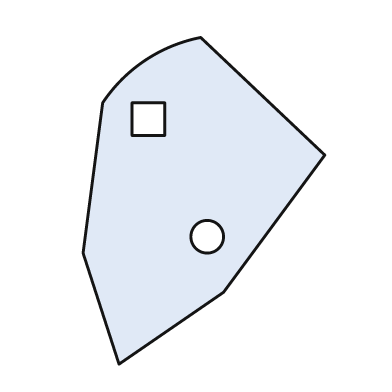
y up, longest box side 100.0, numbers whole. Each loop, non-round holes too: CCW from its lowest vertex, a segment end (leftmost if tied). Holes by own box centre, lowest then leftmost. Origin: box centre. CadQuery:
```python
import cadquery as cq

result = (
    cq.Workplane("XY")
    .moveTo(-26.0, -50.0)
    .lineTo(6.0, -28.0)
    .lineTo(37.0, 14.0)
    .lineTo(-1.0, 50.0)
    .threePointArc((-18.0, 43.0), (-31.0, 30.0))
    .lineTo(-37.0, -16.0)
    .close()
    .moveTo(1.0, -11.0)
    .circle(5.0)
    .moveTo(-22.0, 20.0)
    .lineTo(-12.0, 20.0)
    .lineTo(-12.0, 30.0)
    .lineTo(-22.0, 30.0)
    .close()
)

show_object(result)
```